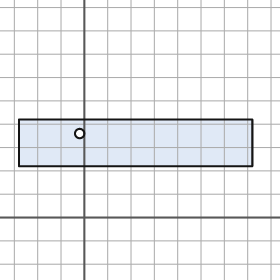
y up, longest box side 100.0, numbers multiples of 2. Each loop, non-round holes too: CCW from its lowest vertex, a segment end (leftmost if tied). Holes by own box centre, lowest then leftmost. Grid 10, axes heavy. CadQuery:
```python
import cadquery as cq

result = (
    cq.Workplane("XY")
    .moveTo(-28.0, 22.0)
    .lineTo(72.0, 22.0)
    .lineTo(72.0, 42.0)
    .lineTo(-28.0, 42.0)
    .close()
    .moveTo(-2.0, 36.0)
    .circle(2.0)
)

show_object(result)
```